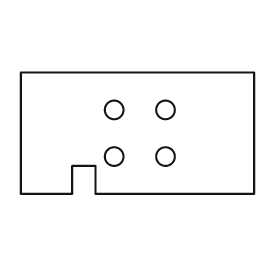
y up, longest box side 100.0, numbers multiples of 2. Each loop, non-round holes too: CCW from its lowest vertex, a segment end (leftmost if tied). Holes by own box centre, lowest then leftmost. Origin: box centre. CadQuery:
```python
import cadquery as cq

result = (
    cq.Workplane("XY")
    .moveTo(-50.0, -26.0)
    .lineTo(-28.0, -26.0)
    .lineTo(-28.0, -14.0)
    .lineTo(-18.0, -14.0)
    .lineTo(-18.0, -26.0)
    .lineTo(50.0, -26.0)
    .lineTo(50.0, 26.0)
    .lineTo(-50.0, 26.0)
    .close()
    .moveTo(-10.0, -10.0)
    .circle(4.0)
    .moveTo(12.0, -10.0)
    .circle(4.0)
    .moveTo(-10.0, 10.0)
    .circle(4.0)
    .moveTo(12.0, 10.0)
    .circle(4.0)
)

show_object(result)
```